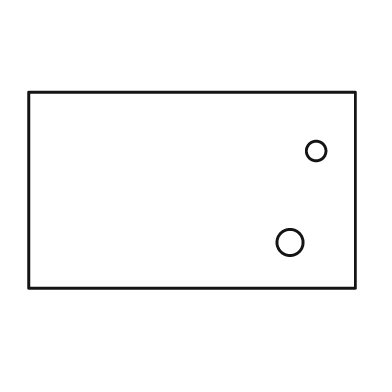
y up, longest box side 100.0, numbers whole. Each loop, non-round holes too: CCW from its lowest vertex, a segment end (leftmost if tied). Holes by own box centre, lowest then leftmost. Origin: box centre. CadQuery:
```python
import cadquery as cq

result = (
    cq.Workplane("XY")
    .moveTo(-50.0, -30.0)
    .lineTo(50.0, -30.0)
    .lineTo(50.0, 30.0)
    .lineTo(-50.0, 30.0)
    .close()
    .moveTo(30.0, -16.0)
    .circle(4.0)
    .moveTo(38.0, 12.0)
    .circle(3.0)
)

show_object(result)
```